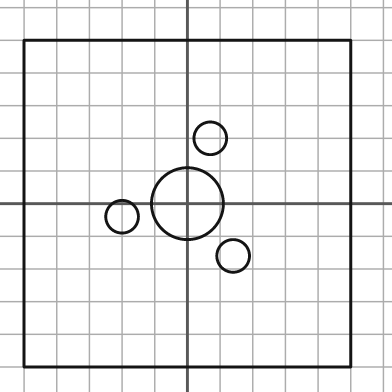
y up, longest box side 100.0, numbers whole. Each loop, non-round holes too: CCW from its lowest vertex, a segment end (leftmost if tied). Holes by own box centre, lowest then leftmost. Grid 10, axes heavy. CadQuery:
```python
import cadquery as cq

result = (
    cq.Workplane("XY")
    .moveTo(-50.0, -50.0)
    .lineTo(50.0, -50.0)
    .lineTo(50.0, 50.0)
    .lineTo(-50.0, 50.0)
    .close()
    .moveTo(14.0, -16.0)
    .circle(5.0)
    .moveTo(-20.0, -4.0)
    .circle(5.0)
    .moveTo(0.0, 0.0)
    .circle(11.0)
    .moveTo(7.0, 20.0)
    .circle(5.0)
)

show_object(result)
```